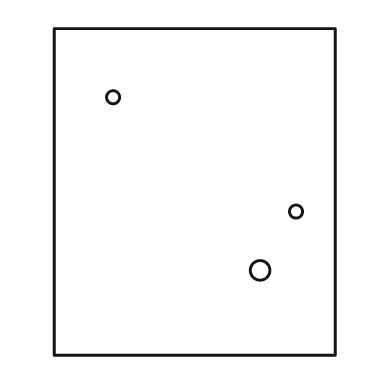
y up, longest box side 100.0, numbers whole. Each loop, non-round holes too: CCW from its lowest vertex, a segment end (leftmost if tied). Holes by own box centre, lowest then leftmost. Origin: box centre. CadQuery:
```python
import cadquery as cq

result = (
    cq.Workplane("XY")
    .moveTo(-43.0, -50.0)
    .lineTo(43.0, -50.0)
    .lineTo(43.0, 50.0)
    .lineTo(-43.0, 50.0)
    .close()
    .moveTo(20.0, -24.0)
    .circle(3.0)
    .moveTo(31.0, -6.0)
    .circle(2.0)
    .moveTo(-25.0, 29.0)
    .circle(2.0)
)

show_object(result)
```